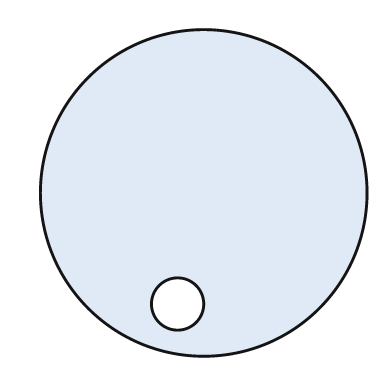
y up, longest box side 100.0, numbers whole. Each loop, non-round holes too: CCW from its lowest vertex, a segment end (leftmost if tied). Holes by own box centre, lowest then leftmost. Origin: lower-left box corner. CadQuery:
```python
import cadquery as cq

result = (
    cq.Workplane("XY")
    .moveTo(50.0, 50.0)
    .circle(50.0)
    .moveTo(42.0, 16.0)
    .circle(8.0)
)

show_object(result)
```